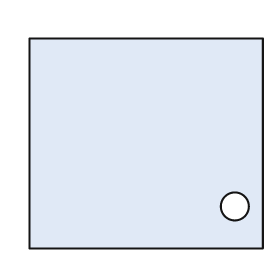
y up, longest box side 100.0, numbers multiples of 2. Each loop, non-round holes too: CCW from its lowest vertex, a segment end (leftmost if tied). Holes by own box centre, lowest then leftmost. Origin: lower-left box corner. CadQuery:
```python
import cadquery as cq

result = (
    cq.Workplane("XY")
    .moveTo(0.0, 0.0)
    .lineTo(100.0, 0.0)
    .lineTo(100.0, 90.0)
    .lineTo(0.0, 90.0)
    .close()
    .moveTo(88.0, 18.0)
    .circle(6.0)
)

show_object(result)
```